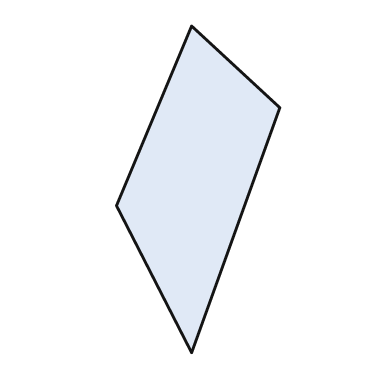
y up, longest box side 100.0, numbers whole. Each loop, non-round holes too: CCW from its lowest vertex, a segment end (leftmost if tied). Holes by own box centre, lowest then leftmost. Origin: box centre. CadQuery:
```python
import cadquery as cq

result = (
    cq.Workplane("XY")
    .moveTo(-2.0, -50.0)
    .lineTo(25.0, 25.0)
    .lineTo(-2.0, 50.0)
    .lineTo(-25.0, -5.0)
    .close()
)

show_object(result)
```